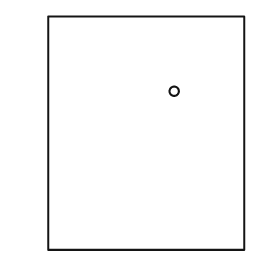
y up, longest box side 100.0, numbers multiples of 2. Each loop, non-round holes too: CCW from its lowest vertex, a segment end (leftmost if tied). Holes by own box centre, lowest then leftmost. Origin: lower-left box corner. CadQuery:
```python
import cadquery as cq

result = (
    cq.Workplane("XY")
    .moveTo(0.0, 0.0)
    .lineTo(84.0, 0.0)
    .lineTo(84.0, 100.0)
    .lineTo(0.0, 100.0)
    .close()
    .moveTo(54.0, 68.0)
    .circle(2.0)
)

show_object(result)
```